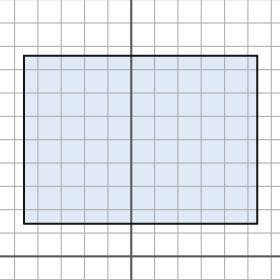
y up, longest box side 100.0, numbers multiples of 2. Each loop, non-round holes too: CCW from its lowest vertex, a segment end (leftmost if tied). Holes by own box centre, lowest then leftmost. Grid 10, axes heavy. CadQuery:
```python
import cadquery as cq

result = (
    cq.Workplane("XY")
    .moveTo(-46.0, 14.0)
    .lineTo(54.0, 14.0)
    .lineTo(54.0, 86.0)
    .lineTo(-46.0, 86.0)
    .close()
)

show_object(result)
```